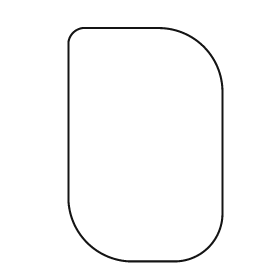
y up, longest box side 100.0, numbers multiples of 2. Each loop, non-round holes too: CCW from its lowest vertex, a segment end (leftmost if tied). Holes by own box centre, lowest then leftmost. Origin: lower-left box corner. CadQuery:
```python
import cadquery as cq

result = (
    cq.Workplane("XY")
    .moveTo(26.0, 0.0)
    .lineTo(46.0, 0.0)
    .threePointArc((60.0, 6.0), (66.0, 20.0))
    .lineTo(66.0, 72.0)
    .threePointArc((58.0, 92.0), (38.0, 100.0))
    .lineTo(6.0, 100.0)
    .threePointArc((2.0, 98.0), (0.0, 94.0))
    .lineTo(0.0, 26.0)
    .threePointArc((8.0, 8.0), (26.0, 0.0))
    .close()
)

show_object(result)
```